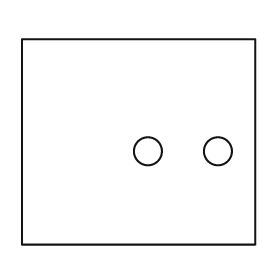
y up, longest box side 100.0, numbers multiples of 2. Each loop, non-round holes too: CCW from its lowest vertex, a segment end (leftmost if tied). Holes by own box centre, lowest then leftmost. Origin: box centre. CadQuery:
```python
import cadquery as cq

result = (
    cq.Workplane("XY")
    .moveTo(-50.0, -44.0)
    .lineTo(50.0, -44.0)
    .lineTo(50.0, 44.0)
    .lineTo(-50.0, 44.0)
    .close()
    .moveTo(4.0, -4.0)
    .circle(6.0)
    .moveTo(34.0, -4.0)
    .circle(6.0)
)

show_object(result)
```